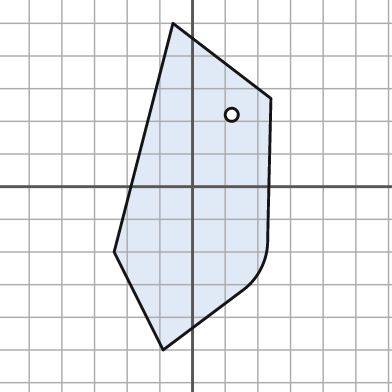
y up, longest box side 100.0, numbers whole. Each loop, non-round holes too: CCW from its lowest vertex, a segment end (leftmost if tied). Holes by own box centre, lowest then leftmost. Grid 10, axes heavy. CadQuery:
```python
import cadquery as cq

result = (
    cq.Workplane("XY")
    .moveTo(-9.0, -50.0)
    .lineTo(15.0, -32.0)
    .threePointArc((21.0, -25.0), (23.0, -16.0))
    .lineTo(24.0, 27.0)
    .lineTo(-6.0, 50.0)
    .lineTo(-24.0, -20.0)
    .close()
    .moveTo(12.0, 22.0)
    .circle(2.0)
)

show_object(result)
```